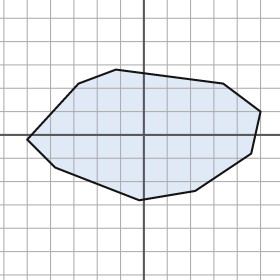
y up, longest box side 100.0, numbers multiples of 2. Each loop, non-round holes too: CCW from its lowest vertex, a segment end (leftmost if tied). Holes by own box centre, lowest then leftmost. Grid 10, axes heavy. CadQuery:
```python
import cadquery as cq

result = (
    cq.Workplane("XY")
    .moveTo(-2.0, -28.0)
    .lineTo(22.0, -24.0)
    .lineTo(46.0, -8.0)
    .lineTo(50.0, 10.0)
    .lineTo(34.0, 22.0)
    .lineTo(-12.0, 28.0)
    .lineTo(-28.0, 22.0)
    .lineTo(-50.0, -2.0)
    .lineTo(-38.0, -14.0)
    .close()
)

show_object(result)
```